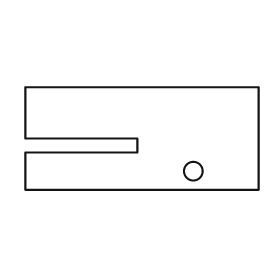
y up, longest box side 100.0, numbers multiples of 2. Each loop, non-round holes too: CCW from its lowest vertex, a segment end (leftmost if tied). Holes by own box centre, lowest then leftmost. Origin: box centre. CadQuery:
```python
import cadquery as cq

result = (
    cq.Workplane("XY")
    .moveTo(-50.0, -22.0)
    .lineTo(50.0, -22.0)
    .lineTo(50.0, 22.0)
    .lineTo(-50.0, 22.0)
    .lineTo(-50.0, 0.0)
    .lineTo(-2.0, 0.0)
    .lineTo(-2.0, -6.0)
    .lineTo(-50.0, -6.0)
    .close()
    .moveTo(22.0, -14.0)
    .circle(4.0)
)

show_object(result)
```